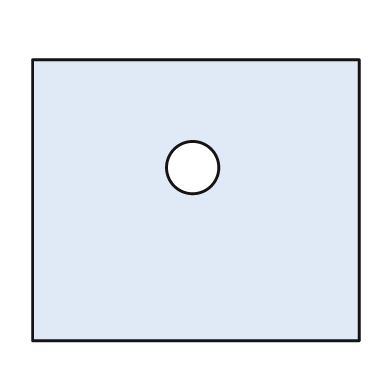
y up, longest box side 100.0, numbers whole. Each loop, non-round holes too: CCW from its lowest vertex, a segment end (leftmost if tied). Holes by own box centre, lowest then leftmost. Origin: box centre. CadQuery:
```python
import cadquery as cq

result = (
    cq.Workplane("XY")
    .moveTo(-50.0, -43.0)
    .lineTo(50.0, -43.0)
    .lineTo(50.0, 43.0)
    .lineTo(-50.0, 43.0)
    .close()
    .moveTo(-1.0, 10.0)
    .circle(8.0)
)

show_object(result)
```